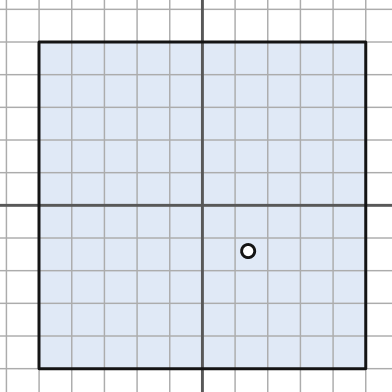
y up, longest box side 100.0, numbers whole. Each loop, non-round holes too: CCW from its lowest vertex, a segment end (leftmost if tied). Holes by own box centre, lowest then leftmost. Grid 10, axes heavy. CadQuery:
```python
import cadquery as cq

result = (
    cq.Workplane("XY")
    .moveTo(-50.0, -50.0)
    .lineTo(50.0, -50.0)
    .lineTo(50.0, 50.0)
    .lineTo(-50.0, 50.0)
    .close()
    .moveTo(14.0, -14.0)
    .circle(2.0)
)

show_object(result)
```